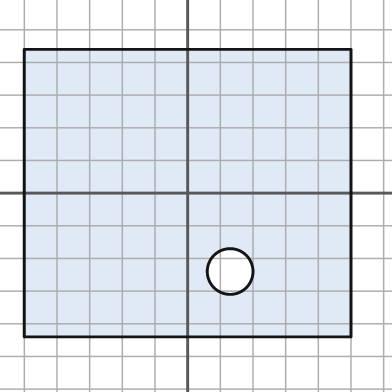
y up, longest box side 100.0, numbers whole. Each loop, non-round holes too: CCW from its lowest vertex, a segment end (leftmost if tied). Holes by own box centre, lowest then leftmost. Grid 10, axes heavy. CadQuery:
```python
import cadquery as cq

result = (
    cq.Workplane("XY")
    .moveTo(-50.0, -44.0)
    .lineTo(50.0, -44.0)
    .lineTo(50.0, 44.0)
    .lineTo(-50.0, 44.0)
    .close()
    .moveTo(13.0, -24.0)
    .circle(7.0)
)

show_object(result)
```